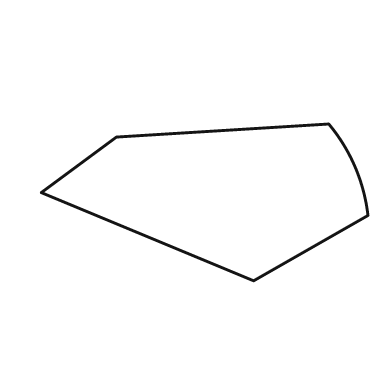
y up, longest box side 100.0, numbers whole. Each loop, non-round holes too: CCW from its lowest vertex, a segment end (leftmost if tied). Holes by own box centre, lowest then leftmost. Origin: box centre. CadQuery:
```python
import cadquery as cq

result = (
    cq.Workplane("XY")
    .moveTo(15.0, -24.0)
    .lineTo(50.0, -4.0)
    .threePointArc((46.0, 11.0), (38.0, 24.0))
    .lineTo(-27.0, 20.0)
    .lineTo(-50.0, 3.0)
    .close()
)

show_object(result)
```